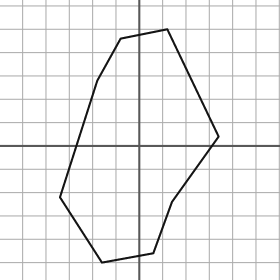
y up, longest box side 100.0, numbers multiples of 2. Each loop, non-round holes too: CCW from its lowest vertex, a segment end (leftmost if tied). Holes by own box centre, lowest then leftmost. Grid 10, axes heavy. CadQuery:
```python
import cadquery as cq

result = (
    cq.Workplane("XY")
    .moveTo(-16.0, -50.0)
    .lineTo(6.0, -46.0)
    .lineTo(14.0, -24.0)
    .lineTo(34.0, 4.0)
    .lineTo(12.0, 50.0)
    .lineTo(-8.0, 46.0)
    .lineTo(-18.0, 28.0)
    .lineTo(-34.0, -22.0)
    .close()
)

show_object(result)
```